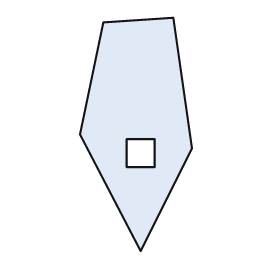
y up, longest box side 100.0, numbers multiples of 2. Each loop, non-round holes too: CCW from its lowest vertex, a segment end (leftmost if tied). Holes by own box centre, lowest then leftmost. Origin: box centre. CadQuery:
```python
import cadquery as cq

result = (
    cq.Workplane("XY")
    .moveTo(2.0, -50.0)
    .lineTo(24.0, -6.0)
    .lineTo(16.0, 50.0)
    .lineTo(-14.0, 48.0)
    .lineTo(-24.0, 0.0)
    .close()
    .moveTo(-4.0, -14.0)
    .lineTo(8.0, -14.0)
    .lineTo(8.0, -2.0)
    .lineTo(-4.0, -2.0)
    .close()
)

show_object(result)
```